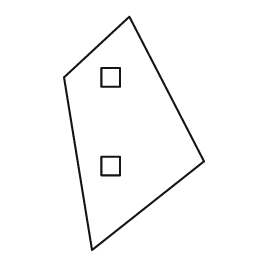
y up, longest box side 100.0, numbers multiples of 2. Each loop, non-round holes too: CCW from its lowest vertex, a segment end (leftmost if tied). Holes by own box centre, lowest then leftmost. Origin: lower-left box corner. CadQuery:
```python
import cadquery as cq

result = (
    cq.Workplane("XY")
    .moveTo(12.0, 0.0)
    .lineTo(60.0, 38.0)
    .lineTo(28.0, 100.0)
    .lineTo(0.0, 74.0)
    .close()
    .moveTo(16.0, 32.0)
    .lineTo(24.0, 32.0)
    .lineTo(24.0, 40.0)
    .lineTo(16.0, 40.0)
    .close()
    .moveTo(16.0, 70.0)
    .lineTo(24.0, 70.0)
    .lineTo(24.0, 78.0)
    .lineTo(16.0, 78.0)
    .close()
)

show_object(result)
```